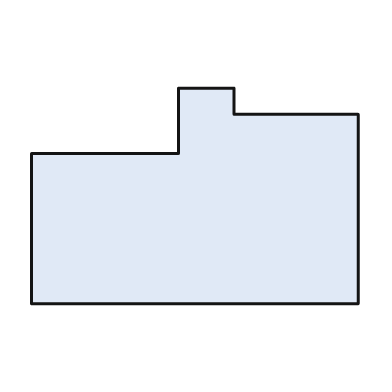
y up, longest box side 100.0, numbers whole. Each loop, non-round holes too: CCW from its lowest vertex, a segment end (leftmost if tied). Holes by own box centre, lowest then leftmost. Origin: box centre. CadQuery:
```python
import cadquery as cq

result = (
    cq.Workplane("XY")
    .moveTo(-50.0, -33.0)
    .lineTo(50.0, -33.0)
    .lineTo(50.0, 25.0)
    .lineTo(12.0, 25.0)
    .lineTo(12.0, 33.0)
    .lineTo(-5.0, 33.0)
    .lineTo(-5.0, 13.0)
    .lineTo(-50.0, 13.0)
    .close()
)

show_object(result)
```